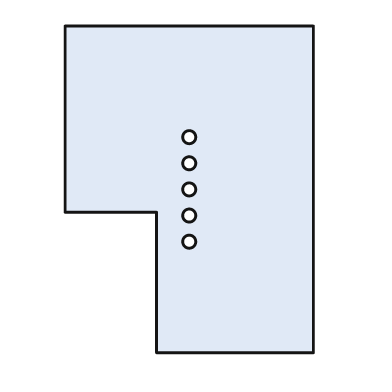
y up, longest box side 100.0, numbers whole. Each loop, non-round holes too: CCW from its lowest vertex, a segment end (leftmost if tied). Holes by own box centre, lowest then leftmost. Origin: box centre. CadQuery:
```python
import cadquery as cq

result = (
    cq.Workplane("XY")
    .moveTo(-10.0, -50.0)
    .lineTo(38.0, -50.0)
    .lineTo(38.0, 50.0)
    .lineTo(-38.0, 50.0)
    .lineTo(-38.0, -7.0)
    .lineTo(-10.0, -7.0)
    .close()
    .moveTo(0.0, -16.0)
    .circle(2.0)
    .moveTo(0.0, -8.0)
    .circle(2.0)
    .moveTo(0.0, 0.0)
    .circle(2.0)
    .moveTo(0.0, 8.0)
    .circle(2.0)
    .moveTo(0.0, 16.0)
    .circle(2.0)
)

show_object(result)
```